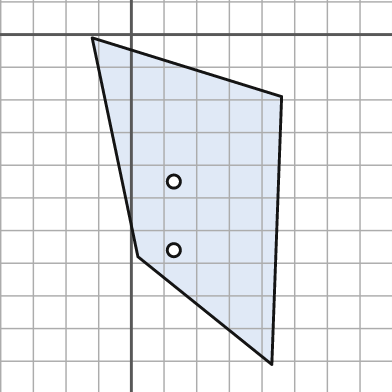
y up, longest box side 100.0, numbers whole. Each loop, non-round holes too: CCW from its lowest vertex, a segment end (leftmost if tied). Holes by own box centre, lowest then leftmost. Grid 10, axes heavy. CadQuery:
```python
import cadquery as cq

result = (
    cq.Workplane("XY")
    .moveTo(43.0, -101.0)
    .lineTo(46.0, -19.0)
    .lineTo(-12.0, -1.0)
    .lineTo(2.0, -68.0)
    .close()
    .moveTo(13.0, -66.0)
    .circle(2.0)
    .moveTo(13.0, -45.0)
    .circle(2.0)
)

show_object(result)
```